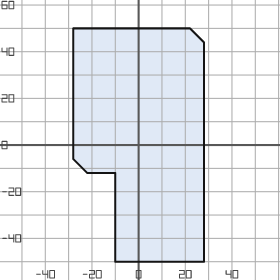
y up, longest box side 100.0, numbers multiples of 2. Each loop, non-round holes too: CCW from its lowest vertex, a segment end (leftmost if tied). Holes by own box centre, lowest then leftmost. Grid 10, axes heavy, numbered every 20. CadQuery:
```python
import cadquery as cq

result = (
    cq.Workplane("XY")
    .moveTo(-10.0, -50.0)
    .lineTo(28.0, -50.0)
    .lineTo(28.0, 44.0)
    .lineTo(22.0, 50.0)
    .lineTo(-28.0, 50.0)
    .lineTo(-28.0, -6.0)
    .lineTo(-22.0, -12.0)
    .lineTo(-10.0, -12.0)
    .close()
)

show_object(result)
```